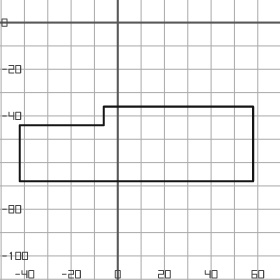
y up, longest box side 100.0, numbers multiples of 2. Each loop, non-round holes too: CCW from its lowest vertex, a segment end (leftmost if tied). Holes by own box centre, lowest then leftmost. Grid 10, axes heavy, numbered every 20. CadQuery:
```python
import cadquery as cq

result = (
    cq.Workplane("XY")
    .moveTo(-42.0, -68.0)
    .lineTo(58.0, -68.0)
    .lineTo(58.0, -36.0)
    .lineTo(-6.0, -36.0)
    .lineTo(-6.0, -44.0)
    .lineTo(-42.0, -44.0)
    .close()
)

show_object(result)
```